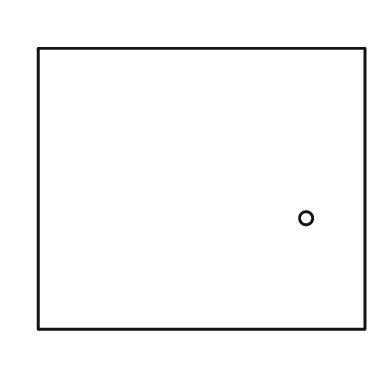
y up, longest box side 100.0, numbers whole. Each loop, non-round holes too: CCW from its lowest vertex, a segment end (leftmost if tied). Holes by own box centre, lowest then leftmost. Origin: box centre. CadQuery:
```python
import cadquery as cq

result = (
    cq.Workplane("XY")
    .moveTo(-50.0, -43.0)
    .lineTo(50.0, -43.0)
    .lineTo(50.0, 43.0)
    .lineTo(-50.0, 43.0)
    .close()
    .moveTo(32.0, -9.0)
    .circle(2.0)
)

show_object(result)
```